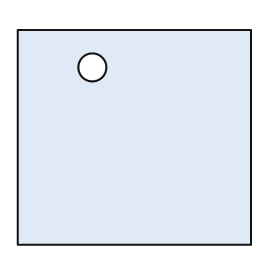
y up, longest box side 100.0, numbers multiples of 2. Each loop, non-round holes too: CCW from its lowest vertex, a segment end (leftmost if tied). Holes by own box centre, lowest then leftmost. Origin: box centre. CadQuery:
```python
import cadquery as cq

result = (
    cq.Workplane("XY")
    .moveTo(-50.0, -46.0)
    .lineTo(50.0, -46.0)
    .lineTo(50.0, 46.0)
    .lineTo(-50.0, 46.0)
    .close()
    .moveTo(-18.0, 30.0)
    .circle(6.0)
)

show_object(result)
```